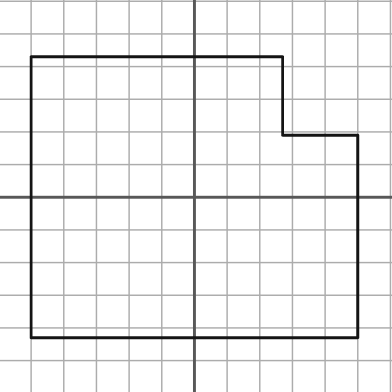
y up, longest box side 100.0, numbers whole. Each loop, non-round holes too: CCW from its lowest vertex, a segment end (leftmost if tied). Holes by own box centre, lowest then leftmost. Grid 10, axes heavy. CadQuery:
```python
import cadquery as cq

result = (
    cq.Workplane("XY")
    .moveTo(-50.0, -43.0)
    .lineTo(50.0, -43.0)
    .lineTo(50.0, 19.0)
    .lineTo(27.0, 19.0)
    .lineTo(27.0, 43.0)
    .lineTo(-50.0, 43.0)
    .close()
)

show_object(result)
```